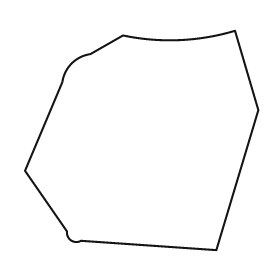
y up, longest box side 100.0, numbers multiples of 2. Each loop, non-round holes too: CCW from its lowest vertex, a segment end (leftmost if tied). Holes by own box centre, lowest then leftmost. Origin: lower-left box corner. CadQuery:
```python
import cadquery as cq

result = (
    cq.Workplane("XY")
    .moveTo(82.0, 0.0)
    .lineTo(100.0, 60.0)
    .lineTo(90.0, 94.0)
    .threePointArc((66.0, 90.0), (42.0, 92.0))
    .lineTo(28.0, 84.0)
    .threePointArc((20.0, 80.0), (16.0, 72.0))
    .lineTo(0.0, 34.0)
    .lineTo(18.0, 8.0)
    .threePointArc((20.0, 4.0), (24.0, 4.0))
    .close()
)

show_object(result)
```